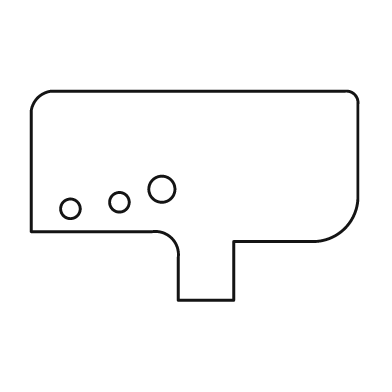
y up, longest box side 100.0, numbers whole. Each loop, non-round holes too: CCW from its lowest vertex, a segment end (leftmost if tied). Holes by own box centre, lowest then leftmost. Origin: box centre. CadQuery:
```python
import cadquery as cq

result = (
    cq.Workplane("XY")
    .moveTo(-5.0, -32.0)
    .lineTo(12.0, -32.0)
    .lineTo(12.0, -14.0)
    .lineTo(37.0, -14.0)
    .threePointArc((46.0, -10.0), (50.0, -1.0))
    .lineTo(50.0, 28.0)
    .threePointArc((49.0, 31.0), (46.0, 32.0))
    .lineTo(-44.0, 32.0)
    .threePointArc((-48.0, 30.0), (-50.0, 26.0))
    .lineTo(-50.0, -11.0)
    .lineTo(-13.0, -11.0)
    .threePointArc((-7.0, -13.0), (-5.0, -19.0))
    .close()
    .moveTo(-38.0, -4.0)
    .circle(3.0)
    .moveTo(-23.0, -2.0)
    .circle(3.0)
    .moveTo(-10.0, 2.0)
    .circle(4.0)
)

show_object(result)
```